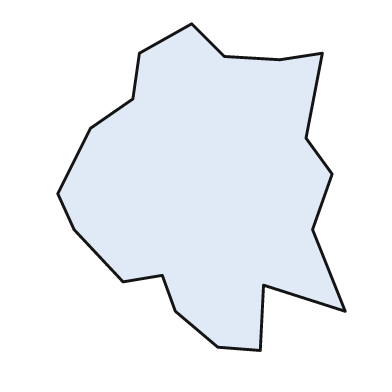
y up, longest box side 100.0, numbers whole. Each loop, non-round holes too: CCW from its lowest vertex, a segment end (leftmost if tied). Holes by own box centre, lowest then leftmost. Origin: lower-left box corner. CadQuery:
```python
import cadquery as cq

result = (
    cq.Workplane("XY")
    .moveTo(62.0, 0.0)
    .lineTo(63.0, 20.0)
    .lineTo(88.0, 12.0)
    .lineTo(78.0, 37.0)
    .lineTo(84.0, 54.0)
    .lineTo(76.0, 65.0)
    .lineTo(81.0, 91.0)
    .lineTo(68.0, 89.0)
    .lineTo(51.0, 90.0)
    .lineTo(41.0, 100.0)
    .lineTo(25.0, 91.0)
    .lineTo(23.0, 77.0)
    .lineTo(10.0, 68.0)
    .lineTo(0.0, 48.0)
    .lineTo(5.0, 37.0)
    .lineTo(20.0, 21.0)
    .lineTo(32.0, 23.0)
    .lineTo(36.0, 12.0)
    .lineTo(49.0, 1.0)
    .close()
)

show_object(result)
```